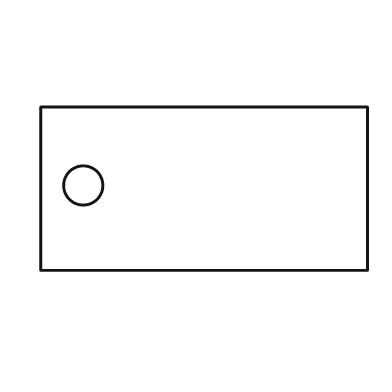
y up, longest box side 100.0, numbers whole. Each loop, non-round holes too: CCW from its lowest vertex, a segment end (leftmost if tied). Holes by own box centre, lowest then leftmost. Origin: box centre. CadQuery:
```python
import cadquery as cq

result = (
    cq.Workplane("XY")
    .moveTo(-50.0, -25.0)
    .lineTo(50.0, -25.0)
    .lineTo(50.0, 25.0)
    .lineTo(-50.0, 25.0)
    .close()
    .moveTo(-37.0, 1.0)
    .circle(6.0)
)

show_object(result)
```